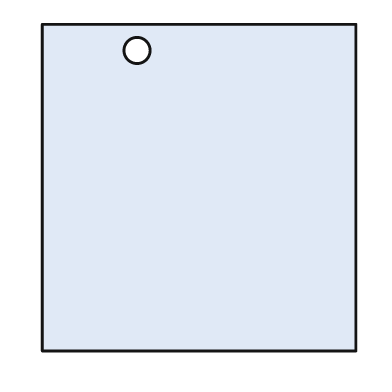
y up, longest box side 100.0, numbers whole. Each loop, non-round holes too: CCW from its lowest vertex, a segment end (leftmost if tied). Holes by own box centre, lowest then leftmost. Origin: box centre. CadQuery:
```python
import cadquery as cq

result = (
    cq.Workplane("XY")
    .moveTo(-48.0, -50.0)
    .lineTo(48.0, -50.0)
    .lineTo(48.0, 50.0)
    .lineTo(-48.0, 50.0)
    .close()
    .moveTo(-19.0, 42.0)
    .circle(4.0)
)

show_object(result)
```